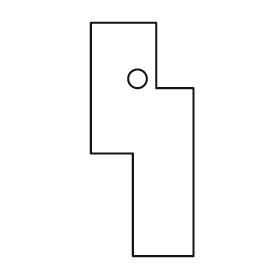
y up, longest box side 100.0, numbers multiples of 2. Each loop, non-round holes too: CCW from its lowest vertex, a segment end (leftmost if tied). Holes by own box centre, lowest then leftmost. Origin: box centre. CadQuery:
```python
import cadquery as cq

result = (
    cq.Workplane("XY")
    .moveTo(-4.0, -50.0)
    .lineTo(22.0, -50.0)
    .lineTo(22.0, 22.0)
    .lineTo(6.0, 22.0)
    .lineTo(6.0, 50.0)
    .lineTo(-22.0, 50.0)
    .lineTo(-22.0, -6.0)
    .lineTo(-4.0, -6.0)
    .close()
    .moveTo(-2.0, 26.0)
    .circle(4.0)
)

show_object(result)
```